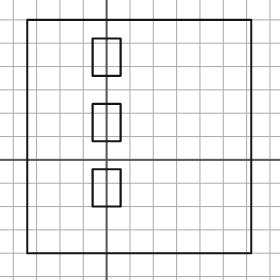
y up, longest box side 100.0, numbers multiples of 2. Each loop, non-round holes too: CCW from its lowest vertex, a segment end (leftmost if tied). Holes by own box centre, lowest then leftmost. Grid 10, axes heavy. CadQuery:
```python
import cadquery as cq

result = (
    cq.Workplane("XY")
    .moveTo(-34.0, -40.0)
    .lineTo(62.0, -40.0)
    .lineTo(62.0, 60.0)
    .lineTo(-34.0, 60.0)
    .close()
    .moveTo(-6.0, -20.0)
    .lineTo(6.0, -20.0)
    .lineTo(6.0, -4.0)
    .lineTo(-6.0, -4.0)
    .close()
    .moveTo(-6.0, 8.0)
    .lineTo(6.0, 8.0)
    .lineTo(6.0, 24.0)
    .lineTo(-6.0, 24.0)
    .close()
    .moveTo(-6.0, 36.0)
    .lineTo(6.0, 36.0)
    .lineTo(6.0, 52.0)
    .lineTo(-6.0, 52.0)
    .close()
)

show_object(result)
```